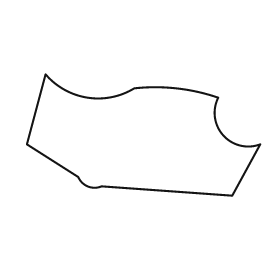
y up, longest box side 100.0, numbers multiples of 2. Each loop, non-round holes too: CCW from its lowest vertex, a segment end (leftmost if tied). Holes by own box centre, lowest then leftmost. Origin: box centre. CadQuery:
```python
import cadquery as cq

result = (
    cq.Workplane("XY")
    .moveTo(38.0, -26.0)
    .lineTo(50.0, -4.0)
    .threePointArc((34.0, 0.0), (32.0, 16.0))
    .threePointArc((14.0, 20.0), (-4.0, 20.0))
    .threePointArc((-24.0, 16.0), (-42.0, 26.0))
    .lineTo(-50.0, -4.0)
    .lineTo(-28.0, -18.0)
    .threePointArc((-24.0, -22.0), (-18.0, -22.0))
    .close()
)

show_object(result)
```